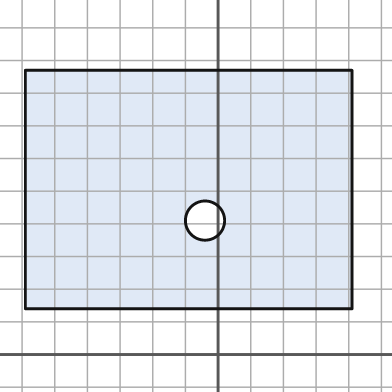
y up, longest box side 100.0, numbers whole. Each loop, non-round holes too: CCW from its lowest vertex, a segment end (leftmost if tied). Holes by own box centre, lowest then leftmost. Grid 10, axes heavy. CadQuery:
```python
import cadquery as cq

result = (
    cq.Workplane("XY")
    .moveTo(-59.0, 14.0)
    .lineTo(41.0, 14.0)
    .lineTo(41.0, 87.0)
    .lineTo(-59.0, 87.0)
    .close()
    .moveTo(-4.0, 41.0)
    .circle(6.0)
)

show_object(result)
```